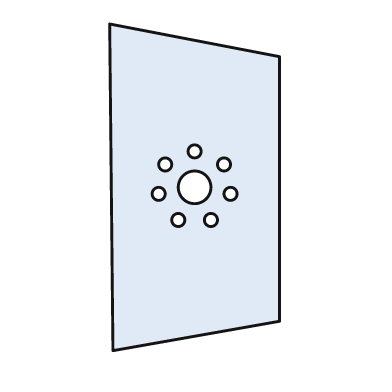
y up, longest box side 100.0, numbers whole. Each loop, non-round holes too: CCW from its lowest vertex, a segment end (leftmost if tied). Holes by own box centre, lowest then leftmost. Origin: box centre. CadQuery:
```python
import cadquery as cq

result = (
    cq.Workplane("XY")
    .moveTo(-25.0, -50.0)
    .lineTo(26.0, -41.0)
    .lineTo(26.0, 40.0)
    .lineTo(-26.0, 50.0)
    .close()
    .moveTo(-5.0, -10.0)
    .circle(2.0)
    .moveTo(5.0, -10.0)
    .circle(2.0)
    .moveTo(-11.0, -2.0)
    .circle(2.0)
    .moveTo(11.0, -2.0)
    .circle(2.0)
    .moveTo(0.0, 0.0)
    .circle(5.0)
    .moveTo(-9.0, 7.0)
    .circle(2.0)
    .moveTo(9.0, 7.0)
    .circle(2.0)
    .moveTo(0.0, 11.0)
    .circle(2.0)
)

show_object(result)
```